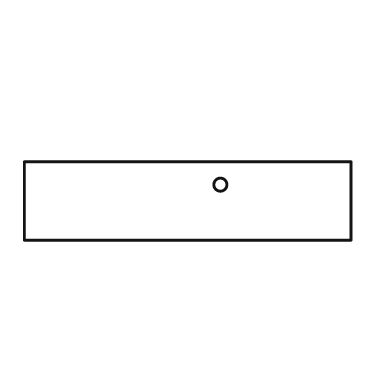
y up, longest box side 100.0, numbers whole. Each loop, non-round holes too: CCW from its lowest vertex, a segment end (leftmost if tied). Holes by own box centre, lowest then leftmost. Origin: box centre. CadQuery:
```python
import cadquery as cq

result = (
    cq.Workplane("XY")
    .moveTo(-50.0, -12.0)
    .lineTo(50.0, -12.0)
    .lineTo(50.0, 12.0)
    .lineTo(-50.0, 12.0)
    .close()
    .moveTo(10.0, 5.0)
    .circle(2.0)
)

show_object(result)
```